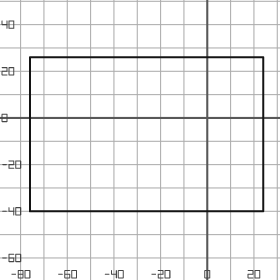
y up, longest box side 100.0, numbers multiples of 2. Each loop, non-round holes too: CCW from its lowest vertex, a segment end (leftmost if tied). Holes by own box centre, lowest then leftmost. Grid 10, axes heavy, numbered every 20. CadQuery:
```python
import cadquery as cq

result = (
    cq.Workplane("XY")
    .moveTo(-76.0, -40.0)
    .lineTo(24.0, -40.0)
    .lineTo(24.0, 26.0)
    .lineTo(-76.0, 26.0)
    .close()
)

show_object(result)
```